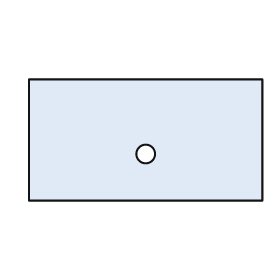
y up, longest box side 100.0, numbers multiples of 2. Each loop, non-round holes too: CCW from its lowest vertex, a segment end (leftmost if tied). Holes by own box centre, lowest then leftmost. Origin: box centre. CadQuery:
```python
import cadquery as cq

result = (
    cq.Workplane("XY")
    .moveTo(-50.0, -26.0)
    .lineTo(50.0, -26.0)
    .lineTo(50.0, 26.0)
    .lineTo(-50.0, 26.0)
    .close()
    .moveTo(0.0, -6.0)
    .circle(4.0)
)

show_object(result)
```